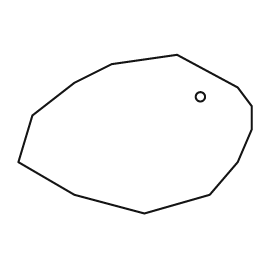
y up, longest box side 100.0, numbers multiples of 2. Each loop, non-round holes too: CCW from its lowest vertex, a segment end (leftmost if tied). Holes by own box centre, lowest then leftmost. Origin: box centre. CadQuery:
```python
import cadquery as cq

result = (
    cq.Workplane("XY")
    .moveTo(4.0, -34.0)
    .lineTo(32.0, -26.0)
    .lineTo(44.0, -12.0)
    .lineTo(50.0, 2.0)
    .lineTo(50.0, 12.0)
    .lineTo(44.0, 20.0)
    .lineTo(18.0, 34.0)
    .lineTo(-10.0, 30.0)
    .lineTo(-26.0, 22.0)
    .lineTo(-44.0, 8.0)
    .lineTo(-50.0, -12.0)
    .lineTo(-26.0, -26.0)
    .close()
    .moveTo(28.0, 16.0)
    .circle(2.0)
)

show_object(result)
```